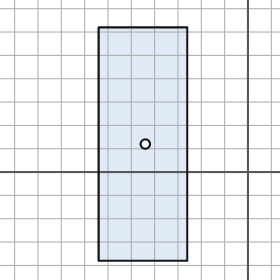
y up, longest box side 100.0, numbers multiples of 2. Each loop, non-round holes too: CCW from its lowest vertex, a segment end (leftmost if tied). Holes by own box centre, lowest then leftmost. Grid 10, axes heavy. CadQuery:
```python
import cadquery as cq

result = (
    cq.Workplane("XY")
    .moveTo(-64.0, -38.0)
    .lineTo(-26.0, -38.0)
    .lineTo(-26.0, 62.0)
    .lineTo(-64.0, 62.0)
    .close()
    .moveTo(-44.0, 12.0)
    .circle(2.0)
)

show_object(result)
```